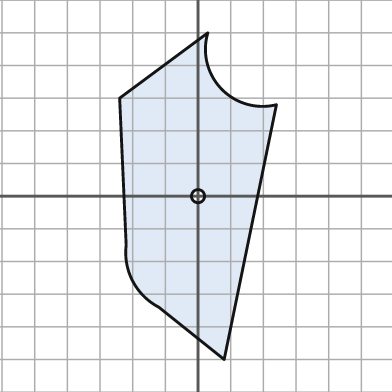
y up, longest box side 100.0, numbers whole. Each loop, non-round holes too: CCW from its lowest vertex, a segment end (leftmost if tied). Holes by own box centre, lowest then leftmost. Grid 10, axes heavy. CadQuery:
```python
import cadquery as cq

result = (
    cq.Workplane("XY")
    .moveTo(8.0, -50.0)
    .lineTo(24.0, 28.0)
    .threePointArc((7.0, 33.0), (3.0, 50.0))
    .lineTo(-24.0, 30.0)
    .lineTo(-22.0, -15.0)
    .threePointArc((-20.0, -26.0), (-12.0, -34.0))
    .close()
    .moveTo(0.0, 0.0)
    .circle(2.0)
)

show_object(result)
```